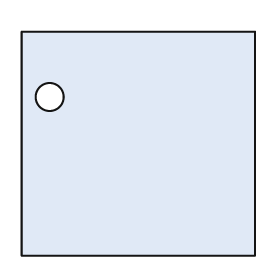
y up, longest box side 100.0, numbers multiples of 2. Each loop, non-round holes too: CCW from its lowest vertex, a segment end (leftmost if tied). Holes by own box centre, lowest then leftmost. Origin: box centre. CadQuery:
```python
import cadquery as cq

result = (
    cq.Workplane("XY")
    .moveTo(-50.0, -48.0)
    .lineTo(50.0, -48.0)
    .lineTo(50.0, 48.0)
    .lineTo(-50.0, 48.0)
    .close()
    .moveTo(-38.0, 20.0)
    .circle(6.0)
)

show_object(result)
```